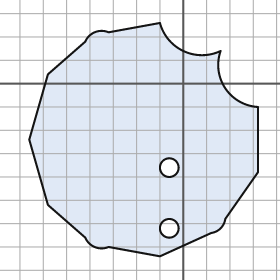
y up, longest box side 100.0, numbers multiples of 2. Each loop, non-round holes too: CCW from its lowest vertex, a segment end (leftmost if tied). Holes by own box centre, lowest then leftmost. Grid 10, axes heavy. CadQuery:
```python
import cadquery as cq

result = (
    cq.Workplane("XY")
    .moveTo(-10.0, -74.0)
    .lineTo(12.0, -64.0)
    .threePointArc((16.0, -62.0), (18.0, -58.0))
    .lineTo(32.0, -38.0)
    .lineTo(32.0, -10.0)
    .threePointArc((18.0, -2.0), (16.0, 14.0))
    .threePointArc((0.0, 14.0), (-10.0, 26.0))
    .lineTo(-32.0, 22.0)
    .threePointArc((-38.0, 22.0), (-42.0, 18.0))
    .lineTo(-58.0, 4.0)
    .lineTo(-66.0, -24.0)
    .lineTo(-58.0, -52.0)
    .lineTo(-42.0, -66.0)
    .threePointArc((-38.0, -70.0), (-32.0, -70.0))
    .close()
    .moveTo(-6.0, -62.0)
    .circle(4.0)
    .moveTo(-6.0, -36.0)
    .circle(4.0)
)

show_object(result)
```